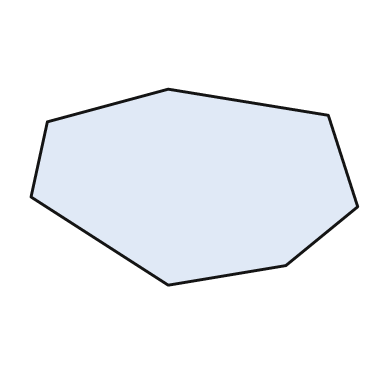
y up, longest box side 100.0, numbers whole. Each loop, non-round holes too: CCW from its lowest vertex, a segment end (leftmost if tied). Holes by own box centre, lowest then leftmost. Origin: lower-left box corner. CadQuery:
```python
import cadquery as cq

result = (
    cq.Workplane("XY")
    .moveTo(42.0, 0.0)
    .lineTo(78.0, 6.0)
    .lineTo(100.0, 24.0)
    .lineTo(91.0, 52.0)
    .lineTo(42.0, 60.0)
    .lineTo(5.0, 50.0)
    .lineTo(0.0, 27.0)
    .close()
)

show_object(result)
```